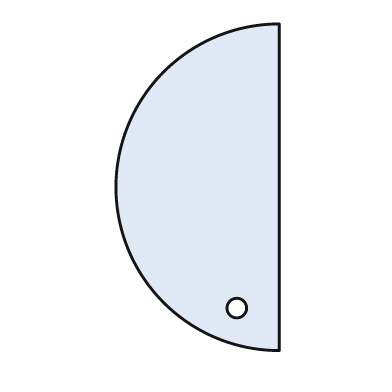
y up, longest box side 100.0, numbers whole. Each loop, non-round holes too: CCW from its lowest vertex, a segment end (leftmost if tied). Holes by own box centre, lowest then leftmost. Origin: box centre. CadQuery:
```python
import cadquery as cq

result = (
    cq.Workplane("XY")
    .moveTo(25.0, -50.0)
    .lineTo(25.0, 50.0)
    .threePointArc((-25.0, 0.0), (25.0, -50.0))
    .close()
    .moveTo(12.0, -37.0)
    .circle(3.0)
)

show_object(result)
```